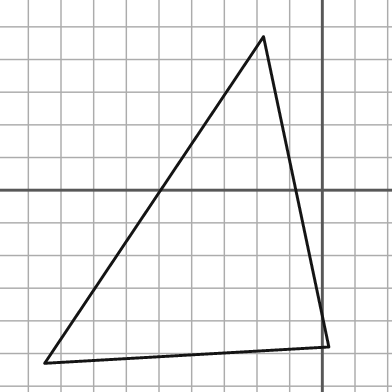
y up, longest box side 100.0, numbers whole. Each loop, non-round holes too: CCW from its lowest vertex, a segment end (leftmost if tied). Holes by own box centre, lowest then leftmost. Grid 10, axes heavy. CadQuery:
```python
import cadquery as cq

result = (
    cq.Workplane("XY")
    .moveTo(-85.0, -53.0)
    .lineTo(2.0, -48.0)
    .lineTo(-18.0, 47.0)
    .close()
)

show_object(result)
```